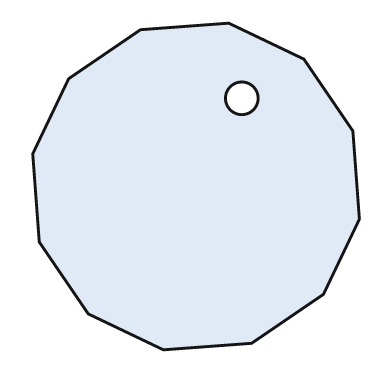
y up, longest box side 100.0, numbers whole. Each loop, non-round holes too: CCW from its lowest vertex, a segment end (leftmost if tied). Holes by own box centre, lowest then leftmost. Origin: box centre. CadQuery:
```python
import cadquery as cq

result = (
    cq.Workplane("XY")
    .moveTo(-10.0, -50.0)
    .lineTo(17.0, -48.0)
    .lineTo(39.0, -33.0)
    .lineTo(50.0, -10.0)
    .lineTo(48.0, 17.0)
    .lineTo(33.0, 39.0)
    .lineTo(10.0, 50.0)
    .lineTo(-17.0, 48.0)
    .lineTo(-39.0, 33.0)
    .lineTo(-50.0, 10.0)
    .lineTo(-48.0, -17.0)
    .lineTo(-33.0, -39.0)
    .close()
    .moveTo(14.0, 27.0)
    .circle(5.0)
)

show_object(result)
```